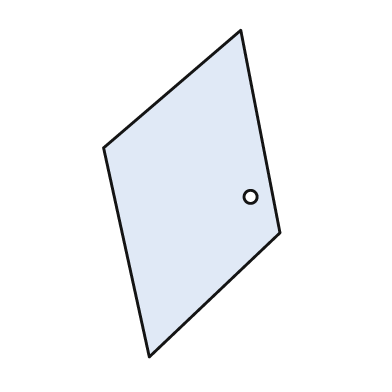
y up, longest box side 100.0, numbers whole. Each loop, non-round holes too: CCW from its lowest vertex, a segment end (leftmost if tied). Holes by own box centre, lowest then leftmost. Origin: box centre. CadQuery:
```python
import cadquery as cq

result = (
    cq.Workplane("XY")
    .moveTo(-13.0, -50.0)
    .lineTo(27.0, -12.0)
    .lineTo(15.0, 50.0)
    .lineTo(-27.0, 14.0)
    .close()
    .moveTo(18.0, -1.0)
    .circle(2.0)
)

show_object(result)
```